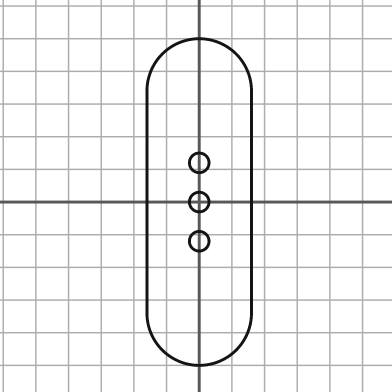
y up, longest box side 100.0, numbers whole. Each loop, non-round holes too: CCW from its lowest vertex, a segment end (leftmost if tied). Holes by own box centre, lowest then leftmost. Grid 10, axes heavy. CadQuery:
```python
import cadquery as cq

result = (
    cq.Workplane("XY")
    .moveTo(-16.0, -34.0)
    .threePointArc((0.0, -50.0), (16.0, -34.0))
    .lineTo(16.0, 34.0)
    .threePointArc((0.0, 50.0), (-16.0, 34.0))
    .close()
    .moveTo(0.0, -12.0)
    .circle(3.0)
    .moveTo(0.0, 0.0)
    .circle(3.0)
    .moveTo(0.0, 12.0)
    .circle(3.0)
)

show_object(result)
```